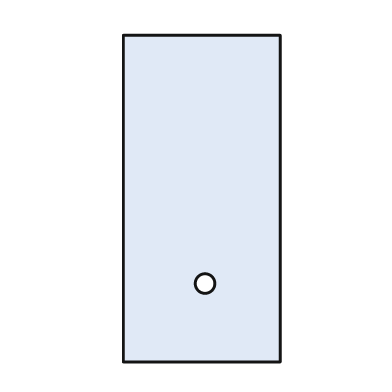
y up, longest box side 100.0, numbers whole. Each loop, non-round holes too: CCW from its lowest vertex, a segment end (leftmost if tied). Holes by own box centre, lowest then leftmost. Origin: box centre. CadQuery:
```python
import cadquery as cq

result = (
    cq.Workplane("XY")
    .moveTo(-24.0, -50.0)
    .lineTo(24.0, -50.0)
    .lineTo(24.0, 50.0)
    .lineTo(-24.0, 50.0)
    .close()
    .moveTo(1.0, -26.0)
    .circle(3.0)
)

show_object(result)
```